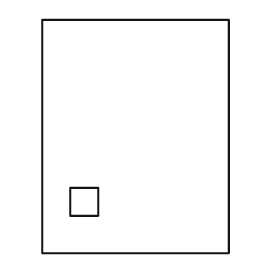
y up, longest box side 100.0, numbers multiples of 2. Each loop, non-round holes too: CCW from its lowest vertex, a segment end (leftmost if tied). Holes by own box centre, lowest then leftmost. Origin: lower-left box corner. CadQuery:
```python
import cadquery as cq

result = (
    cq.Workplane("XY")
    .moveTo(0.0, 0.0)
    .lineTo(80.0, 0.0)
    .lineTo(80.0, 100.0)
    .lineTo(0.0, 100.0)
    .close()
    .moveTo(12.0, 16.0)
    .lineTo(24.0, 16.0)
    .lineTo(24.0, 28.0)
    .lineTo(12.0, 28.0)
    .close()
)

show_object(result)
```